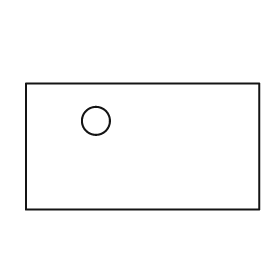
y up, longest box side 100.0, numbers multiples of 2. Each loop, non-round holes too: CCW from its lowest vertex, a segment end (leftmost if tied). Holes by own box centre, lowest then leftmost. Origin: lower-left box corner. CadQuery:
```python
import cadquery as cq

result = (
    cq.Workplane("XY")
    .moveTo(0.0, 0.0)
    .lineTo(100.0, 0.0)
    .lineTo(100.0, 54.0)
    .lineTo(0.0, 54.0)
    .close()
    .moveTo(30.0, 38.0)
    .circle(6.0)
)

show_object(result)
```